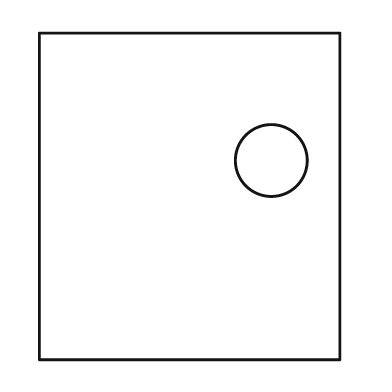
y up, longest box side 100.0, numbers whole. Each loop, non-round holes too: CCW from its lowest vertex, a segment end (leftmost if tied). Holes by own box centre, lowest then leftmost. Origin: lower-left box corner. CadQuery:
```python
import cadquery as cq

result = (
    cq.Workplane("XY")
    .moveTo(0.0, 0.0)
    .lineTo(92.0, 0.0)
    .lineTo(92.0, 100.0)
    .lineTo(0.0, 100.0)
    .close()
    .moveTo(71.0, 61.0)
    .circle(11.0)
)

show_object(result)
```